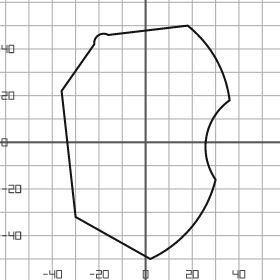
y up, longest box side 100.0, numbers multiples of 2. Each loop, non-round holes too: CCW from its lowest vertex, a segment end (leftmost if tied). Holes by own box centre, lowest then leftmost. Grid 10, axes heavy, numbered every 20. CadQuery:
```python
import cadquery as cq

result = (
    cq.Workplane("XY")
    .moveTo(2.0, -50.0)
    .threePointArc((20.0, -36.0), (30.0, -16.0))
    .threePointArc((26.0, 2.0), (36.0, 18.0))
    .threePointArc((30.0, 36.0), (18.0, 50.0))
    .lineTo(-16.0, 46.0)
    .threePointArc((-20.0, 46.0), (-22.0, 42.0))
    .lineTo(-36.0, 22.0)
    .lineTo(-30.0, -32.0)
    .close()
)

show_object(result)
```